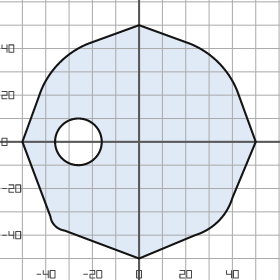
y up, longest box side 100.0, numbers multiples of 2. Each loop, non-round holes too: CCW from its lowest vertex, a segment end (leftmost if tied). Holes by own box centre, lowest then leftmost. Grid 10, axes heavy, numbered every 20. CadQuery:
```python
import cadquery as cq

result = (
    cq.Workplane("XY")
    .moveTo(0.0, -50.0)
    .lineTo(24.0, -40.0)
    .threePointArc((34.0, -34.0), (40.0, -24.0))
    .lineTo(50.0, 0.0)
    .lineTo(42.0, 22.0)
    .threePointArc((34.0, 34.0), (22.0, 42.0))
    .lineTo(0.0, 50.0)
    .lineTo(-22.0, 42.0)
    .threePointArc((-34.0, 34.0), (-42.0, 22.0))
    .lineTo(-50.0, 0.0)
    .lineTo(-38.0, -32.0)
    .threePointArc((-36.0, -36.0), (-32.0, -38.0))
    .close()
    .moveTo(-26.0, 0.0)
    .circle(10.0)
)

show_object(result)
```